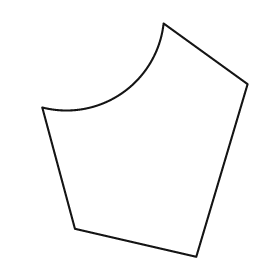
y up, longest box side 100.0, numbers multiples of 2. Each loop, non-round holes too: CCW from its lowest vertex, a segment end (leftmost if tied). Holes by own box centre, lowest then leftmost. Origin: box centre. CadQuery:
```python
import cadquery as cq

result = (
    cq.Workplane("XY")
    .moveTo(22.0, -50.0)
    .lineTo(44.0, 24.0)
    .lineTo(8.0, 50.0)
    .threePointArc((-10.0, 20.0), (-44.0, 14.0))
    .lineTo(-30.0, -38.0)
    .close()
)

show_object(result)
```